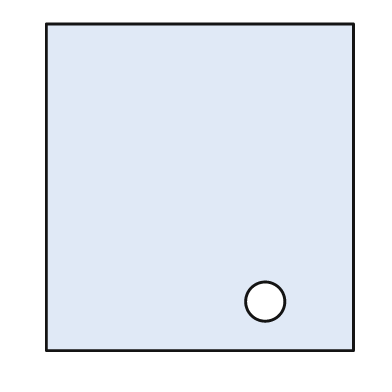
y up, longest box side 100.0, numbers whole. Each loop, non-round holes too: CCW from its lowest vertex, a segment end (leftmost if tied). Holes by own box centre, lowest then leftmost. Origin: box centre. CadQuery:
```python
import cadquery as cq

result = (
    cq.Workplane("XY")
    .moveTo(-47.0, -50.0)
    .lineTo(47.0, -50.0)
    .lineTo(47.0, 50.0)
    .lineTo(-47.0, 50.0)
    .close()
    .moveTo(20.0, -35.0)
    .circle(6.0)
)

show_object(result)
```